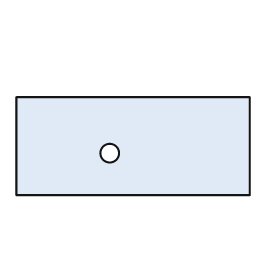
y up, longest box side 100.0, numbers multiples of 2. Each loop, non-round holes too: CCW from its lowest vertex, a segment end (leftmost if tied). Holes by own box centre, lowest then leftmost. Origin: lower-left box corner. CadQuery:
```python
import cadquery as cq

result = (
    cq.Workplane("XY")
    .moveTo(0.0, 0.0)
    .lineTo(100.0, 0.0)
    .lineTo(100.0, 42.0)
    .lineTo(0.0, 42.0)
    .close()
    .moveTo(40.0, 18.0)
    .circle(4.0)
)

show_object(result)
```